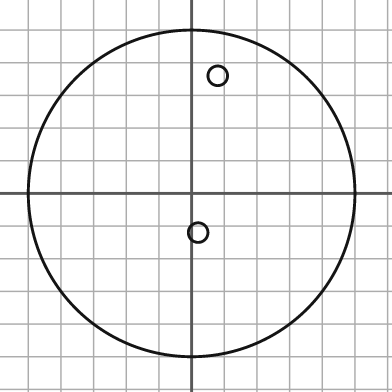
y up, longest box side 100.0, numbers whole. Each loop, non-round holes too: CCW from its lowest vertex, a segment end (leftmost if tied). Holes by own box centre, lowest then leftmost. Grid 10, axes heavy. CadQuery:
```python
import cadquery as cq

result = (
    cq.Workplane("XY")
    .moveTo(0.0, 0.0)
    .circle(50.0)
    .moveTo(2.0, -12.0)
    .circle(3.0)
    .moveTo(8.0, 36.0)
    .circle(3.0)
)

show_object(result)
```